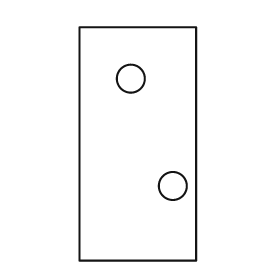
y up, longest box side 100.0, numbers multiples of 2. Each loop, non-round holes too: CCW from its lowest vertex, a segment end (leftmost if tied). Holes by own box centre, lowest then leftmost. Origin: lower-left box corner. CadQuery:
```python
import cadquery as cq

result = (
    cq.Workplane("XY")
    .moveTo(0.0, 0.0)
    .lineTo(50.0, 0.0)
    .lineTo(50.0, 100.0)
    .lineTo(0.0, 100.0)
    .close()
    .moveTo(40.0, 32.0)
    .circle(6.0)
    .moveTo(22.0, 78.0)
    .circle(6.0)
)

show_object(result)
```